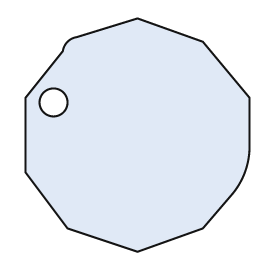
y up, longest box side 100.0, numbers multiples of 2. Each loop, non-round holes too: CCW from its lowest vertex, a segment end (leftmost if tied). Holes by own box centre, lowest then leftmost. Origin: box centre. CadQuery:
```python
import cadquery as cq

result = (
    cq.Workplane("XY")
    .moveTo(0.0, -50.0)
    .lineTo(28.0, -40.0)
    .lineTo(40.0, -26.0)
    .threePointArc((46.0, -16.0), (48.0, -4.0))
    .lineTo(48.0, 16.0)
    .lineTo(28.0, 40.0)
    .lineTo(0.0, 50.0)
    .lineTo(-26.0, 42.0)
    .threePointArc((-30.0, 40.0), (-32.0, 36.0))
    .lineTo(-48.0, 16.0)
    .lineTo(-48.0, -16.0)
    .lineTo(-30.0, -40.0)
    .close()
    .moveTo(-36.0, 14.0)
    .circle(6.0)
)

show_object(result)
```